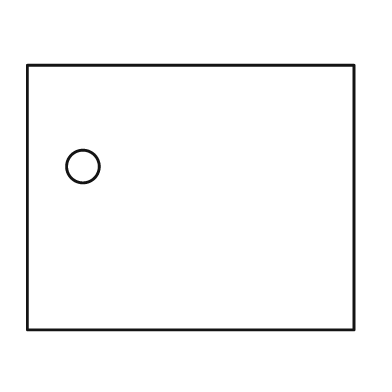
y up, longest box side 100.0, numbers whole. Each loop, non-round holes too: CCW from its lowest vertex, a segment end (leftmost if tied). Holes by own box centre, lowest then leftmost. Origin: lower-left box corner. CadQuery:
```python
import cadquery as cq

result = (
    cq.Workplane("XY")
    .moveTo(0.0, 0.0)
    .lineTo(100.0, 0.0)
    .lineTo(100.0, 81.0)
    .lineTo(0.0, 81.0)
    .close()
    .moveTo(17.0, 50.0)
    .circle(5.0)
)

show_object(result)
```